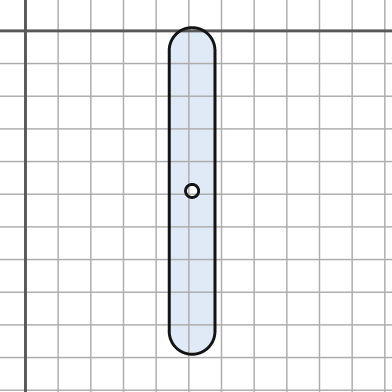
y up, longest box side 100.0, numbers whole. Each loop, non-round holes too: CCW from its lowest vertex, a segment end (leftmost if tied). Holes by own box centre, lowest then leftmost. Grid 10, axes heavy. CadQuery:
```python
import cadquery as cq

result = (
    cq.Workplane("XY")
    .moveTo(44.0, -92.0)
    .threePointArc((51.0, -99.0), (58.0, -92.0))
    .lineTo(58.0, -6.0)
    .threePointArc((51.0, 1.0), (44.0, -6.0))
    .close()
    .moveTo(51.0, -49.0)
    .circle(2.0)
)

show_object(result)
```